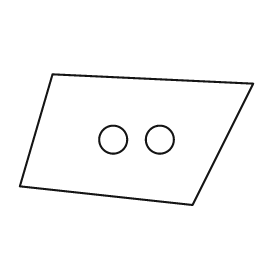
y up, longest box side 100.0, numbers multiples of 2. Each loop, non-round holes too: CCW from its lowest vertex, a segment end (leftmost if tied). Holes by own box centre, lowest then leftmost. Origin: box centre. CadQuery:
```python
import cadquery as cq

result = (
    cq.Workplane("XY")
    .moveTo(24.0, -28.0)
    .lineTo(50.0, 24.0)
    .lineTo(-36.0, 28.0)
    .lineTo(-50.0, -20.0)
    .close()
    .moveTo(-10.0, 0.0)
    .circle(6.0)
    .moveTo(10.0, 0.0)
    .circle(6.0)
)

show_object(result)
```